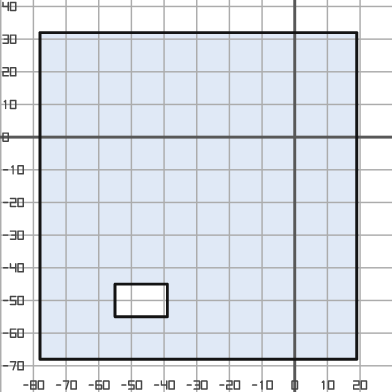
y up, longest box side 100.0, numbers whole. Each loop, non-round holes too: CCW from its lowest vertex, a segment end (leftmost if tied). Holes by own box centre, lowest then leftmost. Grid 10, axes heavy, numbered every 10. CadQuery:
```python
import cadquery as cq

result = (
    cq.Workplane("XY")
    .moveTo(-78.0, -68.0)
    .lineTo(19.0, -68.0)
    .lineTo(19.0, 32.0)
    .lineTo(-78.0, 32.0)
    .close()
    .moveTo(-55.0, -55.0)
    .lineTo(-39.0, -55.0)
    .lineTo(-39.0, -45.0)
    .lineTo(-55.0, -45.0)
    .close()
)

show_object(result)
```